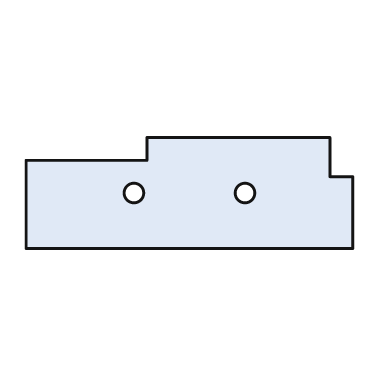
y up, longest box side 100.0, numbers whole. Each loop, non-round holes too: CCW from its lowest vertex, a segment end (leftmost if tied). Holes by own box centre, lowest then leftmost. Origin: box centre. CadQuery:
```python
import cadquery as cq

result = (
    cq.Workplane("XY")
    .moveTo(-50.0, -17.0)
    .lineTo(50.0, -17.0)
    .lineTo(50.0, 5.0)
    .lineTo(43.0, 5.0)
    .lineTo(43.0, 17.0)
    .lineTo(-13.0, 17.0)
    .lineTo(-13.0, 10.0)
    .lineTo(-50.0, 10.0)
    .close()
    .moveTo(-17.0, 0.0)
    .circle(3.0)
    .moveTo(17.0, 0.0)
    .circle(3.0)
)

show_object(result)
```